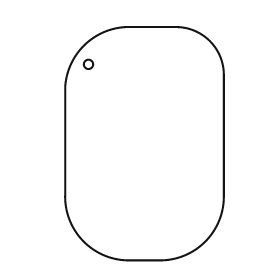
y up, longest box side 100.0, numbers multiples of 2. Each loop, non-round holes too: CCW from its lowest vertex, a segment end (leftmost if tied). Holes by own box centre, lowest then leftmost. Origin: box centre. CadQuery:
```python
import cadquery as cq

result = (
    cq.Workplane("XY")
    .moveTo(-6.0, -50.0)
    .lineTo(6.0, -50.0)
    .threePointArc((26.0, -42.0), (34.0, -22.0))
    .lineTo(34.0, 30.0)
    .threePointArc((28.0, 44.0), (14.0, 50.0))
    .lineTo(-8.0, 50.0)
    .threePointArc((-26.0, 42.0), (-34.0, 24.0))
    .lineTo(-34.0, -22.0)
    .threePointArc((-26.0, -42.0), (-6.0, -50.0))
    .close()
    .moveTo(-24.0, 34.0)
    .circle(2.0)
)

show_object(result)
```